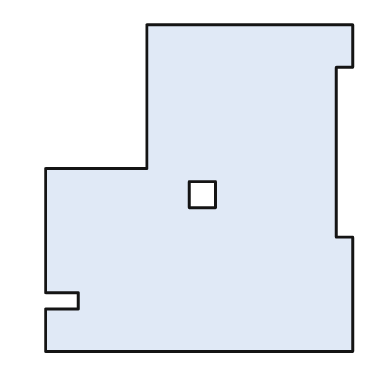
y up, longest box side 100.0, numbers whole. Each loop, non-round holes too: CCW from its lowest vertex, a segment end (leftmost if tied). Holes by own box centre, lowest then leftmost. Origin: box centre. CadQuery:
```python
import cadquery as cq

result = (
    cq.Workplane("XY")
    .moveTo(-47.0, -50.0)
    .lineTo(47.0, -50.0)
    .lineTo(47.0, -15.0)
    .lineTo(42.0, -15.0)
    .lineTo(42.0, 37.0)
    .lineTo(47.0, 37.0)
    .lineTo(47.0, 50.0)
    .lineTo(-16.0, 50.0)
    .lineTo(-16.0, 6.0)
    .lineTo(-47.0, 6.0)
    .lineTo(-47.0, -32.0)
    .lineTo(-37.0, -32.0)
    .lineTo(-37.0, -37.0)
    .lineTo(-47.0, -37.0)
    .close()
    .moveTo(-3.0, -6.0)
    .lineTo(5.0, -6.0)
    .lineTo(5.0, 2.0)
    .lineTo(-3.0, 2.0)
    .close()
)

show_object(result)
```